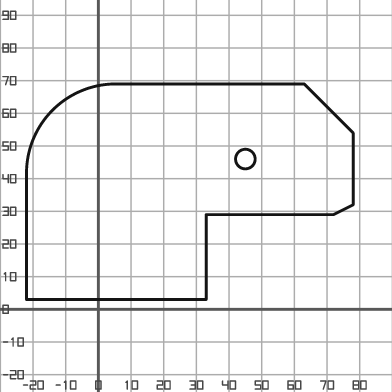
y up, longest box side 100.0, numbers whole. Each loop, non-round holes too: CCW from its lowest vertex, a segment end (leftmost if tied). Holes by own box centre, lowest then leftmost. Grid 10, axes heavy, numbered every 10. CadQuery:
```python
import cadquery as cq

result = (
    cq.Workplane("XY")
    .moveTo(-22.0, 3.0)
    .lineTo(33.0, 3.0)
    .lineTo(33.0, 29.0)
    .lineTo(72.0, 29.0)
    .lineTo(78.0, 32.0)
    .lineTo(78.0, 54.0)
    .lineTo(63.0, 69.0)
    .lineTo(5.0, 69.0)
    .threePointArc((-14.0, 61.0), (-22.0, 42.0))
    .close()
    .moveTo(45.0, 46.0)
    .circle(3.0)
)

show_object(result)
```